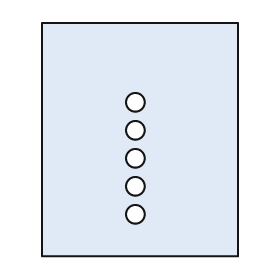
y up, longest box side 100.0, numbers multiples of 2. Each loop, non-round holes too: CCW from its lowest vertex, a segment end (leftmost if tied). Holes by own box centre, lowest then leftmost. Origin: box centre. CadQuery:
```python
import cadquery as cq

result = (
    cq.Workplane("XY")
    .moveTo(-42.0, -50.0)
    .lineTo(42.0, -50.0)
    .lineTo(42.0, 50.0)
    .lineTo(-42.0, 50.0)
    .close()
    .moveTo(-2.0, -32.0)
    .circle(4.0)
    .moveTo(-2.0, -20.0)
    .circle(4.0)
    .moveTo(-2.0, -8.0)
    .circle(4.0)
    .moveTo(-2.0, 4.0)
    .circle(4.0)
    .moveTo(-2.0, 16.0)
    .circle(4.0)
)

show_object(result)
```